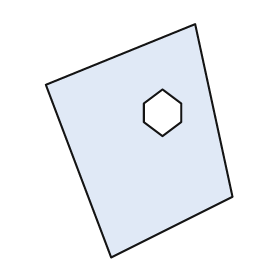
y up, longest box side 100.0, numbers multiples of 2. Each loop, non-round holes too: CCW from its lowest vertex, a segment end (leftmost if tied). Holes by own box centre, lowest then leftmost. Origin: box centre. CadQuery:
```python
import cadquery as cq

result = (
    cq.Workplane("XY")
    .moveTo(-12.0, -50.0)
    .lineTo(40.0, -24.0)
    .lineTo(24.0, 50.0)
    .lineTo(-40.0, 24.0)
    .close()
    .moveTo(10.0, 2.0)
    .lineTo(18.0, 8.0)
    .lineTo(18.0, 16.0)
    .lineTo(10.0, 22.0)
    .lineTo(2.0, 16.0)
    .lineTo(2.0, 8.0)
    .close()
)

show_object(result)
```